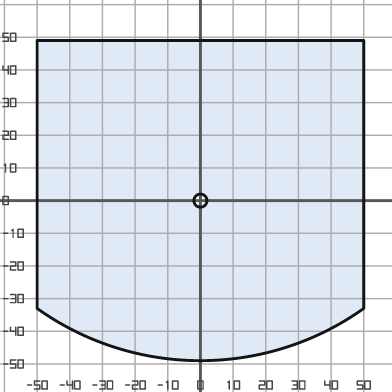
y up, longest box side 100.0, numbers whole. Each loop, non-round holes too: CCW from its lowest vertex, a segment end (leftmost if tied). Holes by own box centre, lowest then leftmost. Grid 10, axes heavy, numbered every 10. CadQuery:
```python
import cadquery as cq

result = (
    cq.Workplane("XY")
    .moveTo(-50.0, -33.0)
    .threePointArc((0.0, -49.0), (50.0, -33.0))
    .lineTo(50.0, 49.0)
    .lineTo(-50.0, 49.0)
    .close()
    .moveTo(0.0, 0.0)
    .circle(2.0)
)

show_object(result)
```